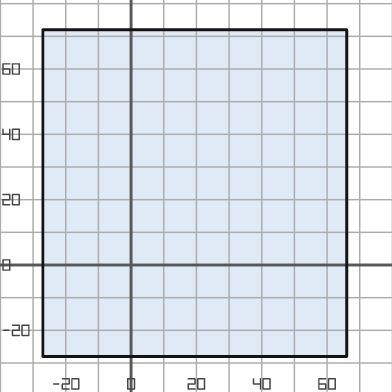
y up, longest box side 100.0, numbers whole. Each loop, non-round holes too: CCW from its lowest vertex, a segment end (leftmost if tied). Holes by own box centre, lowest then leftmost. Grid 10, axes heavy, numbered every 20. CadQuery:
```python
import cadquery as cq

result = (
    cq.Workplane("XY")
    .moveTo(-27.0, -28.0)
    .lineTo(66.0, -28.0)
    .lineTo(66.0, 72.0)
    .lineTo(-27.0, 72.0)
    .close()
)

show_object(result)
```